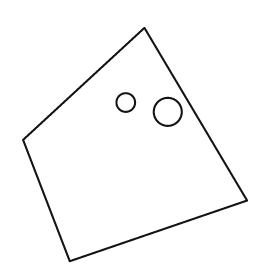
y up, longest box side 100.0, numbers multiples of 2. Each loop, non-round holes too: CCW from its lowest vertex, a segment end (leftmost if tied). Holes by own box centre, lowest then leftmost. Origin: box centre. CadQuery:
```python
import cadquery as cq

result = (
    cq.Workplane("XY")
    .moveTo(-28.0, -50.0)
    .lineTo(48.0, -24.0)
    .lineTo(4.0, 50.0)
    .lineTo(-48.0, 2.0)
    .close()
    .moveTo(14.0, 14.0)
    .circle(6.0)
    .moveTo(-4.0, 18.0)
    .circle(4.0)
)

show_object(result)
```